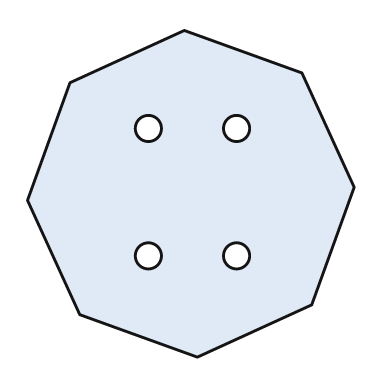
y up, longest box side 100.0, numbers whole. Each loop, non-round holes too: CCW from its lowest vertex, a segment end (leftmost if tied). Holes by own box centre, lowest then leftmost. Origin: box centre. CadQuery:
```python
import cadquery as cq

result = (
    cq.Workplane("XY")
    .moveTo(2.0, -50.0)
    .lineTo(37.0, -34.0)
    .lineTo(50.0, 2.0)
    .lineTo(34.0, 37.0)
    .lineTo(-2.0, 50.0)
    .lineTo(-37.0, 34.0)
    .lineTo(-50.0, -2.0)
    .lineTo(-34.0, -37.0)
    .close()
    .moveTo(-13.0, -19.0)
    .circle(4.0)
    .moveTo(14.0, -19.0)
    .circle(4.0)
    .moveTo(-13.0, 20.0)
    .circle(4.0)
    .moveTo(14.0, 20.0)
    .circle(4.0)
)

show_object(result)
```